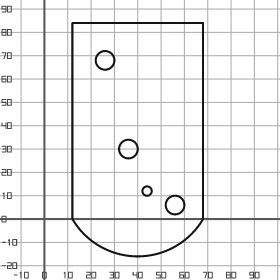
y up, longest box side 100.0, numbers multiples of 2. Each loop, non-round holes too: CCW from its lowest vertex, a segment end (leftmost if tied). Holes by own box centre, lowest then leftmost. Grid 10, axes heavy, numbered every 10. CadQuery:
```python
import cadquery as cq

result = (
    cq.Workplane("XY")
    .moveTo(12.0, 0.0)
    .threePointArc((40.0, -16.0), (68.0, 0.0))
    .lineTo(68.0, 84.0)
    .lineTo(12.0, 84.0)
    .close()
    .moveTo(56.0, 6.0)
    .circle(4.0)
    .moveTo(44.0, 12.0)
    .circle(2.0)
    .moveTo(36.0, 30.0)
    .circle(4.0)
    .moveTo(26.0, 68.0)
    .circle(4.0)
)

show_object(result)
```